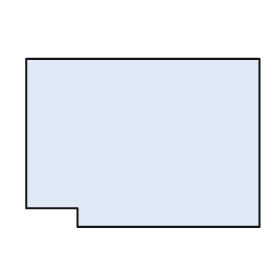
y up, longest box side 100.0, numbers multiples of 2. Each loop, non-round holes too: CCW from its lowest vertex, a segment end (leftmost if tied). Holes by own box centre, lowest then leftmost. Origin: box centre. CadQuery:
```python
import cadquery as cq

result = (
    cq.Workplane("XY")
    .moveTo(-28.0, -36.0)
    .lineTo(50.0, -36.0)
    .lineTo(50.0, 36.0)
    .lineTo(-50.0, 36.0)
    .lineTo(-50.0, -28.0)
    .lineTo(-28.0, -28.0)
    .close()
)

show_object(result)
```